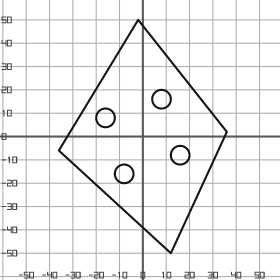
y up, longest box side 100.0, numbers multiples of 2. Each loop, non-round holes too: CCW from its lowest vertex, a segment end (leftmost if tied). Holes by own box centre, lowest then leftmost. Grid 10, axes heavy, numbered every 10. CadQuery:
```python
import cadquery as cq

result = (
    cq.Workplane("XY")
    .moveTo(12.0, -50.0)
    .lineTo(36.0, 2.0)
    .lineTo(-2.0, 50.0)
    .lineTo(-36.0, -6.0)
    .close()
    .moveTo(-8.0, -16.0)
    .circle(4.0)
    .moveTo(16.0, -8.0)
    .circle(4.0)
    .moveTo(-16.0, 8.0)
    .circle(4.0)
    .moveTo(8.0, 16.0)
    .circle(4.0)
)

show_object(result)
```